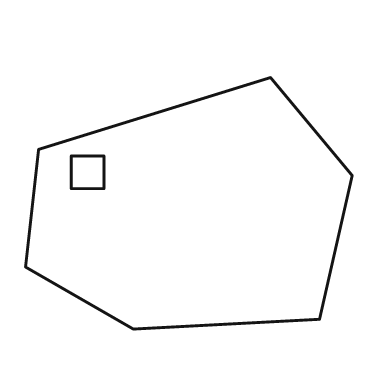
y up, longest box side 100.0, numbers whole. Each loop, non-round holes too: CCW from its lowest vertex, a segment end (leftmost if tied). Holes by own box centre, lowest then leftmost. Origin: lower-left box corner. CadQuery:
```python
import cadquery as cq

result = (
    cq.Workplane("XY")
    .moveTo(33.0, 0.0)
    .lineTo(90.0, 3.0)
    .lineTo(100.0, 47.0)
    .lineTo(75.0, 77.0)
    .lineTo(4.0, 55.0)
    .lineTo(0.0, 19.0)
    .close()
    .moveTo(14.0, 43.0)
    .lineTo(24.0, 43.0)
    .lineTo(24.0, 53.0)
    .lineTo(14.0, 53.0)
    .close()
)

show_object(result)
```